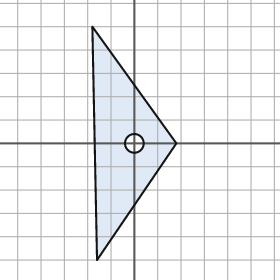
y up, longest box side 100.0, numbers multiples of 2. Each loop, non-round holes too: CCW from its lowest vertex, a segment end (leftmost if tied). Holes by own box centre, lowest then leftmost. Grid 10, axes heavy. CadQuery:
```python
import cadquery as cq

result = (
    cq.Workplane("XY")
    .moveTo(-16.0, -50.0)
    .lineTo(18.0, 0.0)
    .lineTo(-18.0, 50.0)
    .close()
    .moveTo(0.0, 0.0)
    .circle(4.0)
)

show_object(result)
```